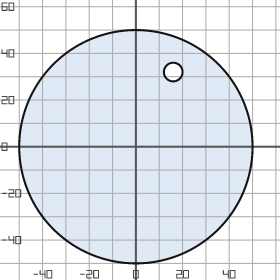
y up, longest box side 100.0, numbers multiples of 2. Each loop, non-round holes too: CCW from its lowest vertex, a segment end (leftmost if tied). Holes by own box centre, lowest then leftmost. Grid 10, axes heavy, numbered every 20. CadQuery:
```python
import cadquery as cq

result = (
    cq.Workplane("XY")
    .moveTo(0.0, 0.0)
    .circle(50.0)
    .moveTo(16.0, 32.0)
    .circle(4.0)
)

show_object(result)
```